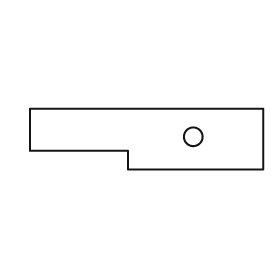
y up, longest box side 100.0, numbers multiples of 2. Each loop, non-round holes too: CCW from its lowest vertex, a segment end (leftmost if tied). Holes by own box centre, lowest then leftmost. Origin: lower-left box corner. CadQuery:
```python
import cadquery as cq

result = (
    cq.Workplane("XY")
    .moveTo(42.0, 0.0)
    .lineTo(100.0, 0.0)
    .lineTo(100.0, 26.0)
    .lineTo(0.0, 26.0)
    .lineTo(0.0, 8.0)
    .lineTo(42.0, 8.0)
    .close()
    .moveTo(70.0, 14.0)
    .circle(4.0)
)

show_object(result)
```